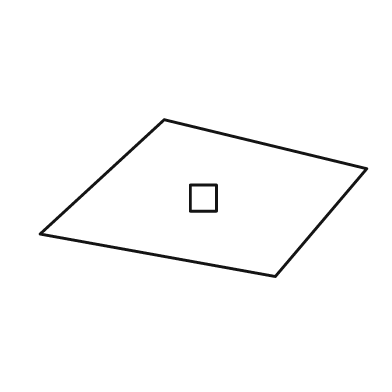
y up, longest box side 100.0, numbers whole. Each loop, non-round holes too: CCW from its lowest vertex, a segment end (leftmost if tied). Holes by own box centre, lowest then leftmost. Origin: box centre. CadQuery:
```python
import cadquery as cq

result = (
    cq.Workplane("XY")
    .moveTo(22.0, -24.0)
    .lineTo(50.0, 9.0)
    .lineTo(-12.0, 24.0)
    .lineTo(-50.0, -11.0)
    .close()
    .moveTo(-4.0, -4.0)
    .lineTo(4.0, -4.0)
    .lineTo(4.0, 4.0)
    .lineTo(-4.0, 4.0)
    .close()
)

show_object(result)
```